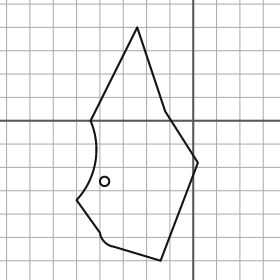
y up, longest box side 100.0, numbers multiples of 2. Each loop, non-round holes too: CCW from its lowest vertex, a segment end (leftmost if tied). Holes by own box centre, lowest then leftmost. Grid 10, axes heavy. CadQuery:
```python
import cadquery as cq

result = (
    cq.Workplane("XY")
    .moveTo(-14.0, -60.0)
    .lineTo(2.0, -18.0)
    .lineTo(-12.0, 4.0)
    .lineTo(-24.0, 40.0)
    .lineTo(-44.0, 0.0)
    .threePointArc((-42.0, -18.0), (-50.0, -34.0))
    .lineTo(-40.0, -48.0)
    .threePointArc((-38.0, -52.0), (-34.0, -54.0))
    .close()
    .moveTo(-38.0, -26.0)
    .circle(2.0)
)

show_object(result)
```